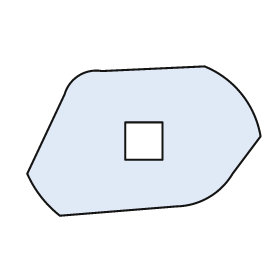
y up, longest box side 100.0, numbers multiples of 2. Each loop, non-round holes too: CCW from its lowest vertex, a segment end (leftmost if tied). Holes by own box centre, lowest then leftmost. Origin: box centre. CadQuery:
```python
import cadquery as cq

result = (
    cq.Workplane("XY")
    .moveTo(-36.0, -32.0)
    .lineTo(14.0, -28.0)
    .threePointArc((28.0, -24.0), (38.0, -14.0))
    .lineTo(50.0, 2.0)
    .threePointArc((42.0, 20.0), (26.0, 32.0))
    .lineTo(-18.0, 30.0)
    .threePointArc((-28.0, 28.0), (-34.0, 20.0))
    .lineTo(-50.0, -14.0)
    .threePointArc((-44.0, -24.0), (-36.0, -32.0))
    .close()
    .moveTo(-8.0, -8.0)
    .lineTo(8.0, -8.0)
    .lineTo(8.0, 8.0)
    .lineTo(-8.0, 8.0)
    .close()
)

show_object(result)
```